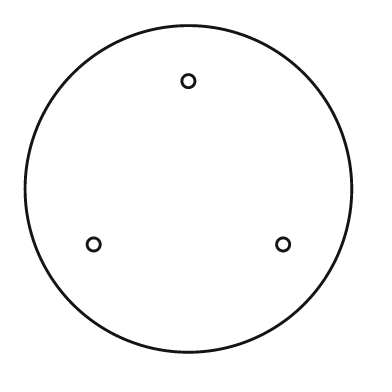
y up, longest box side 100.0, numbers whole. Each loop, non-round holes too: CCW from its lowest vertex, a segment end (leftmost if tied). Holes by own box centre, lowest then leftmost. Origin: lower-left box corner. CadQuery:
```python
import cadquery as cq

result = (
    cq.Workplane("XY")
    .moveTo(50.0, 50.0)
    .circle(50.0)
    .moveTo(21.0, 33.0)
    .circle(2.0)
    .moveTo(79.0, 33.0)
    .circle(2.0)
    .moveTo(50.0, 83.0)
    .circle(2.0)
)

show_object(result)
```